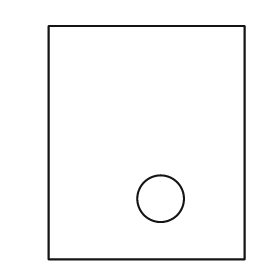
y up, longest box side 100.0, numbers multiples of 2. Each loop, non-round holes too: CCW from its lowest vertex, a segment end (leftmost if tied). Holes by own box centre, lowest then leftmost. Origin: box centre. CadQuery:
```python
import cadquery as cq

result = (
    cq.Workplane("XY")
    .moveTo(-42.0, -50.0)
    .lineTo(42.0, -50.0)
    .lineTo(42.0, 50.0)
    .lineTo(-42.0, 50.0)
    .close()
    .moveTo(6.0, -24.0)
    .circle(10.0)
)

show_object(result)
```